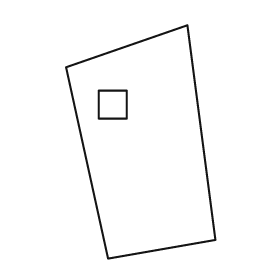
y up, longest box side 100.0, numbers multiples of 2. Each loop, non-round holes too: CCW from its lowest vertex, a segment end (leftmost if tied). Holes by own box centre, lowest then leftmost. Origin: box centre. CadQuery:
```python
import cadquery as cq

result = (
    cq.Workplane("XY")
    .moveTo(-14.0, -50.0)
    .lineTo(32.0, -42.0)
    .lineTo(20.0, 50.0)
    .lineTo(-32.0, 32.0)
    .close()
    .moveTo(-18.0, 10.0)
    .lineTo(-6.0, 10.0)
    .lineTo(-6.0, 22.0)
    .lineTo(-18.0, 22.0)
    .close()
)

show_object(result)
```